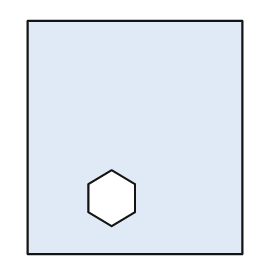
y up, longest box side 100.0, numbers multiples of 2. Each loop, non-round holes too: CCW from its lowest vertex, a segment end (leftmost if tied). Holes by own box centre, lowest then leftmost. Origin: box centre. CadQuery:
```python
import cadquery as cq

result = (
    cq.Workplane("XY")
    .moveTo(-46.0, -50.0)
    .lineTo(46.0, -50.0)
    .lineTo(46.0, 50.0)
    .lineTo(-46.0, 50.0)
    .close()
    .moveTo(-10.0, -38.0)
    .lineTo(0.0, -32.0)
    .lineTo(0.0, -20.0)
    .lineTo(-10.0, -14.0)
    .lineTo(-20.0, -20.0)
    .lineTo(-20.0, -32.0)
    .close()
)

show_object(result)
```